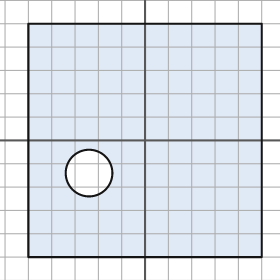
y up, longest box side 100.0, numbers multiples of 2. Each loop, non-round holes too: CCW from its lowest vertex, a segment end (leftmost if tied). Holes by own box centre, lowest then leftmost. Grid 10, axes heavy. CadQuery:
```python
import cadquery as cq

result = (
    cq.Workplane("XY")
    .moveTo(-50.0, -50.0)
    .lineTo(50.0, -50.0)
    .lineTo(50.0, 50.0)
    .lineTo(-50.0, 50.0)
    .close()
    .moveTo(-24.0, -14.0)
    .circle(10.0)
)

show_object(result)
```